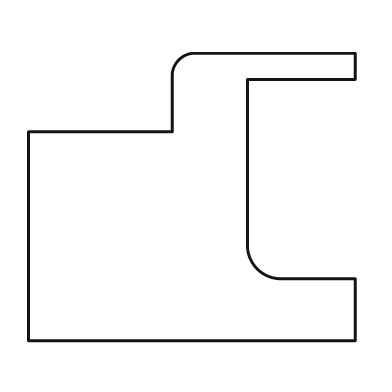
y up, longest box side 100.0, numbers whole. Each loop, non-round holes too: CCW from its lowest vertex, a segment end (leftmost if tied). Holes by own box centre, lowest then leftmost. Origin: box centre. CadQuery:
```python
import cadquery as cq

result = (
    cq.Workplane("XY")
    .moveTo(-50.0, -44.0)
    .lineTo(50.0, -44.0)
    .lineTo(50.0, -25.0)
    .lineTo(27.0, -25.0)
    .threePointArc((20.0, -22.0), (17.0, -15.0))
    .lineTo(17.0, 36.0)
    .lineTo(50.0, 36.0)
    .lineTo(50.0, 44.0)
    .lineTo(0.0, 44.0)
    .threePointArc((-4.0, 42.0), (-6.0, 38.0))
    .lineTo(-6.0, 20.0)
    .lineTo(-50.0, 20.0)
    .close()
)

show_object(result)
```